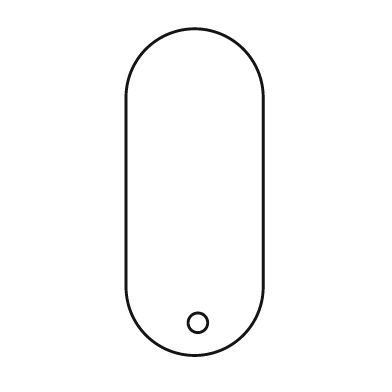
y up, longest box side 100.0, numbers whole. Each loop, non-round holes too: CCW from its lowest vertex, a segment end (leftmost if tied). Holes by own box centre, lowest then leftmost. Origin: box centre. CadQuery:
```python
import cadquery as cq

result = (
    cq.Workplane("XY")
    .moveTo(-21.0, -29.0)
    .threePointArc((0.0, -50.0), (21.0, -29.0))
    .lineTo(21.0, 29.0)
    .threePointArc((0.0, 50.0), (-21.0, 29.0))
    .close()
    .moveTo(1.0, -40.0)
    .circle(3.0)
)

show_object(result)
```